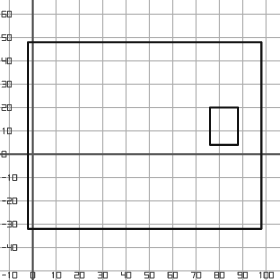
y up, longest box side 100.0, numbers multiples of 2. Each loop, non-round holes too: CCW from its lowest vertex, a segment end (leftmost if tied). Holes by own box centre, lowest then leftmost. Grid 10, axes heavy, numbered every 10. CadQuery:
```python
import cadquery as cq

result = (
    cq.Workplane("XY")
    .moveTo(-2.0, -32.0)
    .lineTo(98.0, -32.0)
    .lineTo(98.0, 48.0)
    .lineTo(-2.0, 48.0)
    .close()
    .moveTo(76.0, 4.0)
    .lineTo(88.0, 4.0)
    .lineTo(88.0, 20.0)
    .lineTo(76.0, 20.0)
    .close()
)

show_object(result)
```